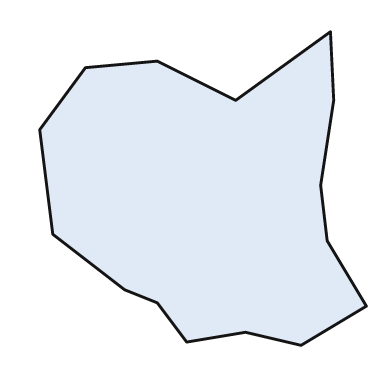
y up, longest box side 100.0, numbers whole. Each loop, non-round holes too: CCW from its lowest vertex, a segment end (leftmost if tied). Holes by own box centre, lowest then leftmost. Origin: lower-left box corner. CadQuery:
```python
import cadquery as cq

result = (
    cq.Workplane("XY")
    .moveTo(80.0, 0.0)
    .lineTo(100.0, 12.0)
    .lineTo(88.0, 32.0)
    .lineTo(86.0, 49.0)
    .lineTo(90.0, 75.0)
    .lineTo(89.0, 96.0)
    .lineTo(60.0, 75.0)
    .lineTo(36.0, 87.0)
    .lineTo(14.0, 85.0)
    .lineTo(0.0, 66.0)
    .lineTo(4.0, 34.0)
    .lineTo(26.0, 17.0)
    .lineTo(36.0, 13.0)
    .lineTo(45.0, 1.0)
    .lineTo(63.0, 4.0)
    .close()
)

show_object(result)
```